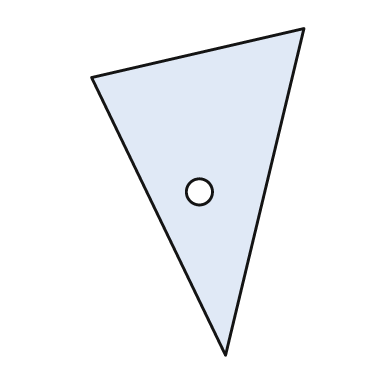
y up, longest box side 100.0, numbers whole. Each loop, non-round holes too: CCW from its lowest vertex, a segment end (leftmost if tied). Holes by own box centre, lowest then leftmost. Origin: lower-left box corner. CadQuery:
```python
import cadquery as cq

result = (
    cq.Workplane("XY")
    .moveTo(41.0, 0.0)
    .lineTo(65.0, 100.0)
    .lineTo(0.0, 85.0)
    .close()
    .moveTo(33.0, 50.0)
    .circle(4.0)
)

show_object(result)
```